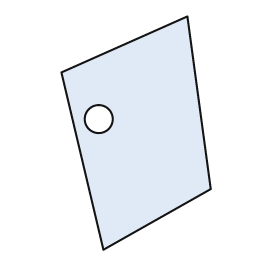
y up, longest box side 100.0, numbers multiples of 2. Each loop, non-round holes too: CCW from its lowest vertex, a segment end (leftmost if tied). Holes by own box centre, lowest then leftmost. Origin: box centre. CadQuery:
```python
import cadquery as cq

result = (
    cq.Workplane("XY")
    .moveTo(-14.0, -50.0)
    .lineTo(32.0, -24.0)
    .lineTo(22.0, 50.0)
    .lineTo(-32.0, 26.0)
    .close()
    .moveTo(-16.0, 6.0)
    .circle(6.0)
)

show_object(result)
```